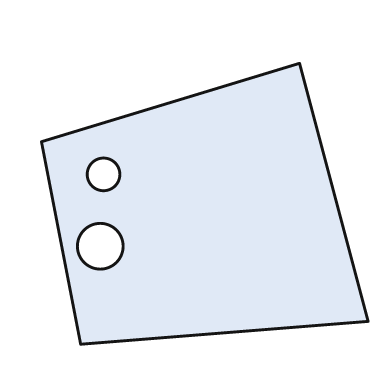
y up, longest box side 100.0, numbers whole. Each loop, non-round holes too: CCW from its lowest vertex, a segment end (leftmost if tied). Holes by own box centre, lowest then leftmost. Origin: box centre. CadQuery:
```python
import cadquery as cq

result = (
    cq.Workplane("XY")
    .moveTo(-38.0, -43.0)
    .lineTo(50.0, -36.0)
    .lineTo(29.0, 43.0)
    .lineTo(-50.0, 19.0)
    .close()
    .moveTo(-32.0, -13.0)
    .circle(7.0)
    .moveTo(-31.0, 9.0)
    .circle(5.0)
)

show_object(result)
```